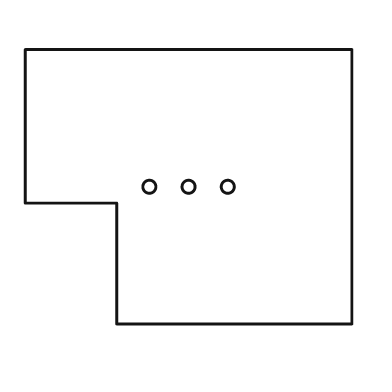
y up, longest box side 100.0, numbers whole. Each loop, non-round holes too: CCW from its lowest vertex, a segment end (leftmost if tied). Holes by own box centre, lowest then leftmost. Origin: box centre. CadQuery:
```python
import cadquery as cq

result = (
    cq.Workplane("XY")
    .moveTo(-22.0, -42.0)
    .lineTo(50.0, -42.0)
    .lineTo(50.0, 42.0)
    .lineTo(-50.0, 42.0)
    .lineTo(-50.0, -5.0)
    .lineTo(-22.0, -5.0)
    .close()
    .moveTo(-12.0, 0.0)
    .circle(2.0)
    .moveTo(0.0, 0.0)
    .circle(2.0)
    .moveTo(12.0, 0.0)
    .circle(2.0)
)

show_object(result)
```